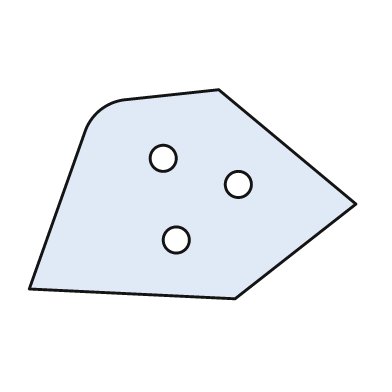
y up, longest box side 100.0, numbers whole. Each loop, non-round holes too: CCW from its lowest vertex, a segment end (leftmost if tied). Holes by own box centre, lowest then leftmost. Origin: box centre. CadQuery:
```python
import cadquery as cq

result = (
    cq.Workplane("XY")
    .moveTo(13.0, -32.0)
    .lineTo(50.0, -3.0)
    .lineTo(8.0, 32.0)
    .lineTo(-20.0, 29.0)
    .threePointArc((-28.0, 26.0), (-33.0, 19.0))
    .lineTo(-50.0, -29.0)
    .close()
    .moveTo(-5.0, -14.0)
    .circle(4.0)
    .moveTo(14.0, 3.0)
    .circle(4.0)
    .moveTo(-9.0, 11.0)
    .circle(4.0)
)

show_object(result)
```